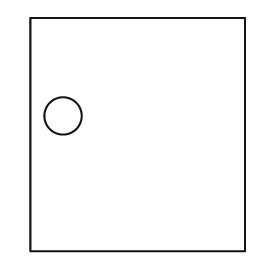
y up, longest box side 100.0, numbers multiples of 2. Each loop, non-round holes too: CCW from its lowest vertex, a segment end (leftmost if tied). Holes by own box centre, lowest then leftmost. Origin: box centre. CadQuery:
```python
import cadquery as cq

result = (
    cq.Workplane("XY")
    .moveTo(-46.0, -50.0)
    .lineTo(46.0, -50.0)
    .lineTo(46.0, 50.0)
    .lineTo(-46.0, 50.0)
    .close()
    .moveTo(-32.0, 8.0)
    .circle(8.0)
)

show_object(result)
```